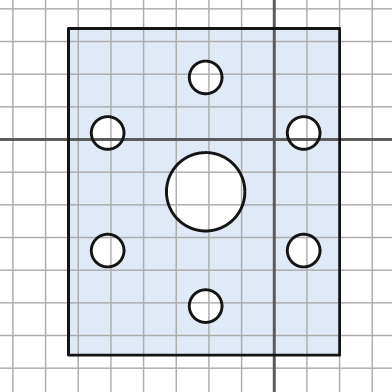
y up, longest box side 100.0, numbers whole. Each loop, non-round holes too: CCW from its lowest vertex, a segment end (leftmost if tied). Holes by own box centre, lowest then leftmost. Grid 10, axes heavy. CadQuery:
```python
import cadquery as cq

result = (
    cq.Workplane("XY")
    .moveTo(-63.0, -66.0)
    .lineTo(20.0, -66.0)
    .lineTo(20.0, 34.0)
    .lineTo(-63.0, 34.0)
    .close()
    .moveTo(-21.0, -51.0)
    .circle(5.0)
    .moveTo(-51.0, -34.0)
    .circle(5.0)
    .moveTo(9.0, -34.0)
    .circle(5.0)
    .moveTo(-21.0, -16.0)
    .circle(12.0)
    .moveTo(-51.0, 2.0)
    .circle(5.0)
    .moveTo(9.0, 2.0)
    .circle(5.0)
    .moveTo(-21.0, 19.0)
    .circle(5.0)
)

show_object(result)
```